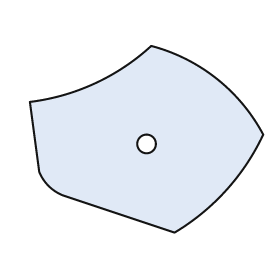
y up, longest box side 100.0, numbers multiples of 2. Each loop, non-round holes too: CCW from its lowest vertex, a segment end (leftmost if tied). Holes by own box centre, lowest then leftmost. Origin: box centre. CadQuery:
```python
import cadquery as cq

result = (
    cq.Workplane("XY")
    .moveTo(12.0, -40.0)
    .threePointArc((34.0, -22.0), (50.0, 2.0))
    .threePointArc((30.0, 26.0), (2.0, 40.0))
    .threePointArc((-22.0, 24.0), (-50.0, 16.0))
    .lineTo(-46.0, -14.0)
    .threePointArc((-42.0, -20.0), (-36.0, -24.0))
    .close()
    .moveTo(0.0, -2.0)
    .circle(4.0)
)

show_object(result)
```